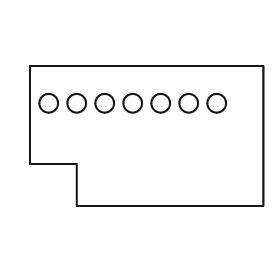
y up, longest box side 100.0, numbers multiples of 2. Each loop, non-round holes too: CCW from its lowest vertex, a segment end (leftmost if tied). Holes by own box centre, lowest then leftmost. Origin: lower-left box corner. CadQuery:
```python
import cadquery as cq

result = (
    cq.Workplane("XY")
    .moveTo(20.0, 0.0)
    .lineTo(100.0, 0.0)
    .lineTo(100.0, 60.0)
    .lineTo(0.0, 60.0)
    .lineTo(0.0, 18.0)
    .lineTo(20.0, 18.0)
    .close()
    .moveTo(8.0, 44.0)
    .circle(4.0)
    .moveTo(20.0, 44.0)
    .circle(4.0)
    .moveTo(32.0, 44.0)
    .circle(4.0)
    .moveTo(44.0, 44.0)
    .circle(4.0)
    .moveTo(56.0, 44.0)
    .circle(4.0)
    .moveTo(68.0, 44.0)
    .circle(4.0)
    .moveTo(80.0, 44.0)
    .circle(4.0)
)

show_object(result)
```